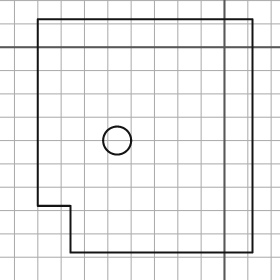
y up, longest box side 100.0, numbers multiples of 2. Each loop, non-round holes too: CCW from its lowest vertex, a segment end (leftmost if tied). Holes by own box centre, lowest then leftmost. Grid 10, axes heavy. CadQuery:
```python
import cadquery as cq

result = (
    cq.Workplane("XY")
    .moveTo(-66.0, -88.0)
    .lineTo(12.0, -88.0)
    .lineTo(12.0, 12.0)
    .lineTo(-80.0, 12.0)
    .lineTo(-80.0, -68.0)
    .lineTo(-66.0, -68.0)
    .close()
    .moveTo(-46.0, -40.0)
    .circle(6.0)
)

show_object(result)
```